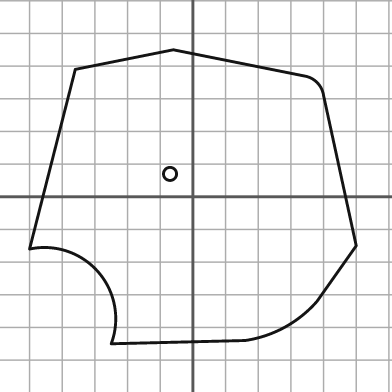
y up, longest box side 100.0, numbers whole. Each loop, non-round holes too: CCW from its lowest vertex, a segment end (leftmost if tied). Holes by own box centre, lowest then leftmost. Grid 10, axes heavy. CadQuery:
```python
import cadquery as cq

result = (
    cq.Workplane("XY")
    .moveTo(-25.0, -45.0)
    .lineTo(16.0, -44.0)
    .threePointArc((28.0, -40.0), (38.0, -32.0))
    .lineTo(50.0, -15.0)
    .lineTo(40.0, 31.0)
    .threePointArc((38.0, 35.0), (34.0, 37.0))
    .lineTo(-6.0, 45.0)
    .lineTo(-36.0, 39.0)
    .lineTo(-50.0, -16.0)
    .threePointArc((-29.0, -23.0), (-25.0, -45.0))
    .close()
    .moveTo(-7.0, 7.0)
    .circle(2.0)
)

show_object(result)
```